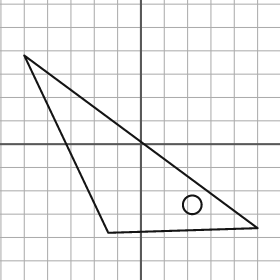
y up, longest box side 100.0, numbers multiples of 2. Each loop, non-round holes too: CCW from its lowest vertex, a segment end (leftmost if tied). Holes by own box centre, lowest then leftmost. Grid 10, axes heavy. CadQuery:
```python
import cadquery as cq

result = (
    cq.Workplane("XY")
    .moveTo(-14.0, -38.0)
    .lineTo(50.0, -36.0)
    .lineTo(-50.0, 38.0)
    .close()
    .moveTo(22.0, -26.0)
    .circle(4.0)
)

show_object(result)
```